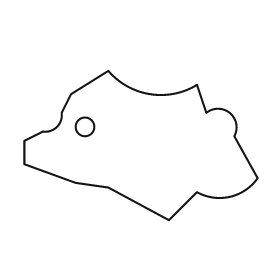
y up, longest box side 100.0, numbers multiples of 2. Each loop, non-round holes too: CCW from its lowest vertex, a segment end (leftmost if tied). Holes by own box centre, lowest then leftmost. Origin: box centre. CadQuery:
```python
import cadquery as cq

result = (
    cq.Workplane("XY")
    .moveTo(12.0, -32.0)
    .lineTo(24.0, -20.0)
    .threePointArc((38.0, -22.0), (50.0, -14.0))
    .lineTo(40.0, 4.0)
    .threePointArc((38.0, 14.0), (28.0, 14.0))
    .lineTo(24.0, 26.0)
    .threePointArc((4.0, 22.0), (-14.0, 32.0))
    .lineTo(-30.0, 22.0)
    .lineTo(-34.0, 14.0)
    .threePointArc((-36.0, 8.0), (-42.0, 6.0))
    .lineTo(-50.0, 2.0)
    .lineTo(-50.0, -8.0)
    .lineTo(-28.0, -16.0)
    .lineTo(-14.0, -18.0)
    .close()
    .moveTo(-24.0, 8.0)
    .circle(4.0)
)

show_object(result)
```